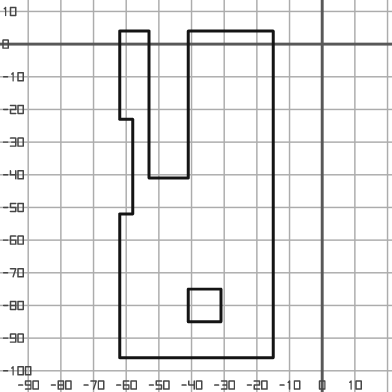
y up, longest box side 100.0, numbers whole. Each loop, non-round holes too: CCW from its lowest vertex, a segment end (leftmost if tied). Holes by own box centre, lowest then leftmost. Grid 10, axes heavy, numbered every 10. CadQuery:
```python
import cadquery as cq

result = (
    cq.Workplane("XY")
    .moveTo(-62.0, -96.0)
    .lineTo(-15.0, -96.0)
    .lineTo(-15.0, 4.0)
    .lineTo(-41.0, 4.0)
    .lineTo(-41.0, -41.0)
    .lineTo(-53.0, -41.0)
    .lineTo(-53.0, 4.0)
    .lineTo(-62.0, 4.0)
    .lineTo(-62.0, -23.0)
    .lineTo(-58.0, -23.0)
    .lineTo(-58.0, -52.0)
    .lineTo(-62.0, -52.0)
    .close()
    .moveTo(-41.0, -85.0)
    .lineTo(-31.0, -85.0)
    .lineTo(-31.0, -75.0)
    .lineTo(-41.0, -75.0)
    .close()
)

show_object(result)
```